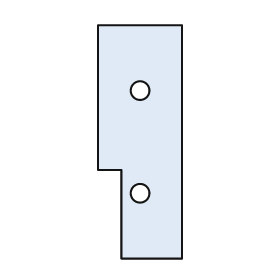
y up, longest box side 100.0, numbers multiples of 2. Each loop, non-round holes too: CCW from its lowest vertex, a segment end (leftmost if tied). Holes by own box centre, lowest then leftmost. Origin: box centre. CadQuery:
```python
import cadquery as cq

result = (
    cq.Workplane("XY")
    .moveTo(-8.0, -50.0)
    .lineTo(18.0, -50.0)
    .lineTo(18.0, 50.0)
    .lineTo(-18.0, 50.0)
    .lineTo(-18.0, -12.0)
    .lineTo(-8.0, -12.0)
    .close()
    .moveTo(0.0, -22.0)
    .circle(4.0)
    .moveTo(0.0, 22.0)
    .circle(4.0)
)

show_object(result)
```